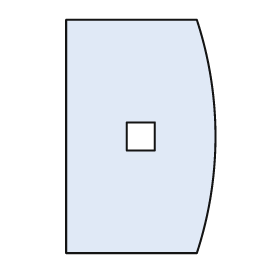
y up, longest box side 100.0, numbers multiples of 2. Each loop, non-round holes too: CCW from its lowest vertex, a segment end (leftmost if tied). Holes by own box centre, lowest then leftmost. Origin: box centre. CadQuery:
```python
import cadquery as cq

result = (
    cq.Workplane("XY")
    .moveTo(-32.0, -50.0)
    .lineTo(24.0, -50.0)
    .threePointArc((32.0, 0.0), (24.0, 50.0))
    .lineTo(-32.0, 50.0)
    .close()
    .moveTo(-6.0, -6.0)
    .lineTo(6.0, -6.0)
    .lineTo(6.0, 6.0)
    .lineTo(-6.0, 6.0)
    .close()
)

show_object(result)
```